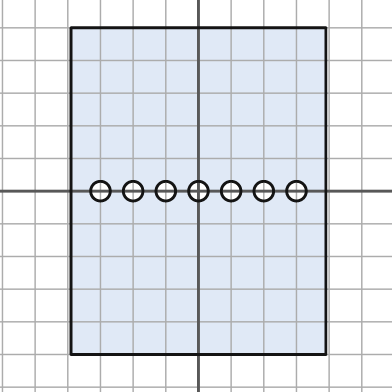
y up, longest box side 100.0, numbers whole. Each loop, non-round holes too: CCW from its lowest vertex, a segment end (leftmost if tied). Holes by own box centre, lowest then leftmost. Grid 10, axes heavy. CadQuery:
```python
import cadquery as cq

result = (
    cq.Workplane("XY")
    .moveTo(-39.0, -50.0)
    .lineTo(39.0, -50.0)
    .lineTo(39.0, 50.0)
    .lineTo(-39.0, 50.0)
    .close()
    .moveTo(-30.0, 0.0)
    .circle(3.0)
    .moveTo(-20.0, 0.0)
    .circle(3.0)
    .moveTo(-10.0, 0.0)
    .circle(3.0)
    .moveTo(0.0, 0.0)
    .circle(3.0)
    .moveTo(10.0, 0.0)
    .circle(3.0)
    .moveTo(20.0, 0.0)
    .circle(3.0)
    .moveTo(30.0, 0.0)
    .circle(3.0)
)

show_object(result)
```